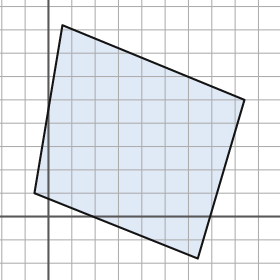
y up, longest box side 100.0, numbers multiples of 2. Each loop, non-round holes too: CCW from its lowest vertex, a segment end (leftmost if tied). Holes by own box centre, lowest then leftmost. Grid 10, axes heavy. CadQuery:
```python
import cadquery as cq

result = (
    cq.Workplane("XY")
    .moveTo(64.0, -18.0)
    .lineTo(84.0, 50.0)
    .lineTo(6.0, 82.0)
    .lineTo(-6.0, 10.0)
    .close()
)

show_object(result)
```